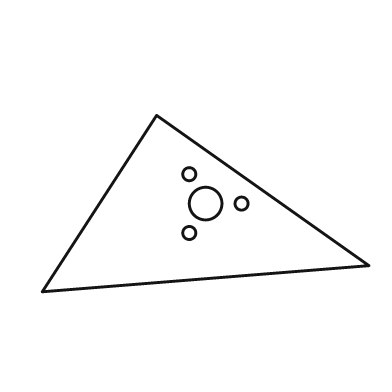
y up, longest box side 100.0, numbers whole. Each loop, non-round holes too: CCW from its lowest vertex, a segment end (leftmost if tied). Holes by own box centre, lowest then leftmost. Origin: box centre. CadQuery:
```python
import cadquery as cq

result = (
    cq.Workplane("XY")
    .moveTo(-50.0, -27.0)
    .lineTo(50.0, -19.0)
    .lineTo(-15.0, 27.0)
    .close()
    .moveTo(-5.0, -9.0)
    .circle(2.0)
    .moveTo(0.0, 0.0)
    .circle(5.0)
    .moveTo(11.0, 0.0)
    .circle(2.0)
    .moveTo(-5.0, 9.0)
    .circle(2.0)
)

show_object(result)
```